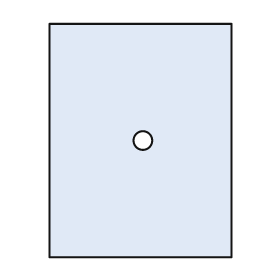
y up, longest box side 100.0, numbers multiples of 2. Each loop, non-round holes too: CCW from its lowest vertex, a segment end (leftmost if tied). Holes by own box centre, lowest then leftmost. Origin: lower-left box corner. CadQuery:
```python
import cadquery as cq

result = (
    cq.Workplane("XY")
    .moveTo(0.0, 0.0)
    .lineTo(78.0, 0.0)
    .lineTo(78.0, 100.0)
    .lineTo(0.0, 100.0)
    .close()
    .moveTo(40.0, 50.0)
    .circle(4.0)
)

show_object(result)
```